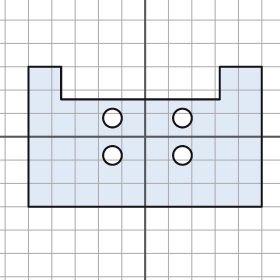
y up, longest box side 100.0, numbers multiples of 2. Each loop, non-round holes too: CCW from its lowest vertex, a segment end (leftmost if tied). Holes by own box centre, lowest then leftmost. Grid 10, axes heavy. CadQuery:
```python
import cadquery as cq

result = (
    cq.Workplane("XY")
    .moveTo(-50.0, -30.0)
    .lineTo(50.0, -30.0)
    .lineTo(50.0, 30.0)
    .lineTo(32.0, 30.0)
    .lineTo(32.0, 16.0)
    .lineTo(-36.0, 16.0)
    .lineTo(-36.0, 30.0)
    .lineTo(-50.0, 30.0)
    .close()
    .moveTo(-14.0, -8.0)
    .circle(4.0)
    .moveTo(16.0, -8.0)
    .circle(4.0)
    .moveTo(-14.0, 8.0)
    .circle(4.0)
    .moveTo(16.0, 8.0)
    .circle(4.0)
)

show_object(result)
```